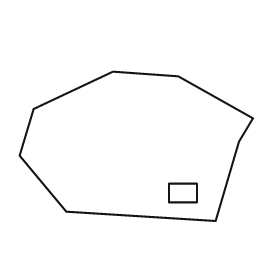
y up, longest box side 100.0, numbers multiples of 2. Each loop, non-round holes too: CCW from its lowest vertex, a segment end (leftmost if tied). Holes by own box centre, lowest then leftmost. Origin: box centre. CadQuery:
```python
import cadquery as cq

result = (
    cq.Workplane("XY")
    .moveTo(34.0, -32.0)
    .lineTo(44.0, 2.0)
    .lineTo(50.0, 12.0)
    .lineTo(18.0, 30.0)
    .lineTo(-10.0, 32.0)
    .lineTo(-44.0, 16.0)
    .lineTo(-50.0, -4.0)
    .lineTo(-30.0, -28.0)
    .close()
    .moveTo(14.0, -24.0)
    .lineTo(26.0, -24.0)
    .lineTo(26.0, -16.0)
    .lineTo(14.0, -16.0)
    .close()
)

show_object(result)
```